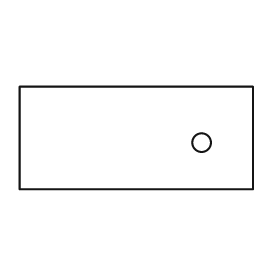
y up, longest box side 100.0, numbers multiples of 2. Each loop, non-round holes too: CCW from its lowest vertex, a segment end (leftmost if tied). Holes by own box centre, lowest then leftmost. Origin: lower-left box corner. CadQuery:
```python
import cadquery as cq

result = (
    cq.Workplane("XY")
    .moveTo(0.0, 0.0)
    .lineTo(100.0, 0.0)
    .lineTo(100.0, 44.0)
    .lineTo(0.0, 44.0)
    .close()
    .moveTo(78.0, 20.0)
    .circle(4.0)
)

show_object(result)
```